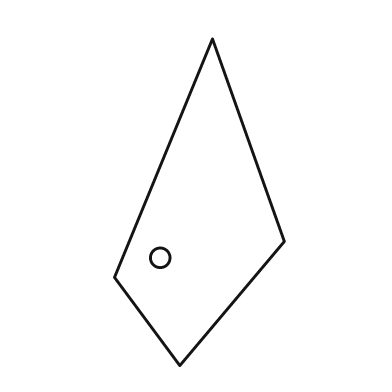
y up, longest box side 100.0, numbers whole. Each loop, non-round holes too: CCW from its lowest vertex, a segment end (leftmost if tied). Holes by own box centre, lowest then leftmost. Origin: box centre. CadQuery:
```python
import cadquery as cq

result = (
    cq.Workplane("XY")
    .moveTo(-6.0, -50.0)
    .lineTo(26.0, -12.0)
    .lineTo(4.0, 50.0)
    .lineTo(-26.0, -23.0)
    .close()
    .moveTo(-12.0, -17.0)
    .circle(3.0)
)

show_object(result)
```